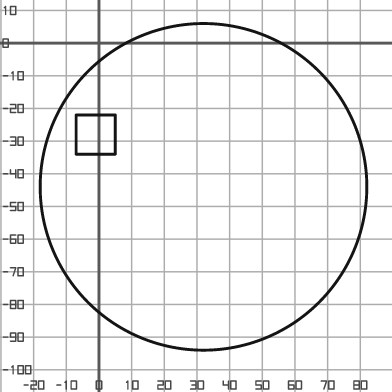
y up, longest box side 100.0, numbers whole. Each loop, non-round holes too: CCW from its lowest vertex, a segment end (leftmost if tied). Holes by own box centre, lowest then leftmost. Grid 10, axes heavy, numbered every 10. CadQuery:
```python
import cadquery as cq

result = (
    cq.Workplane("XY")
    .moveTo(32.0, -44.0)
    .circle(50.0)
    .moveTo(-7.0, -34.0)
    .lineTo(5.0, -34.0)
    .lineTo(5.0, -22.0)
    .lineTo(-7.0, -22.0)
    .close()
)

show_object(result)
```